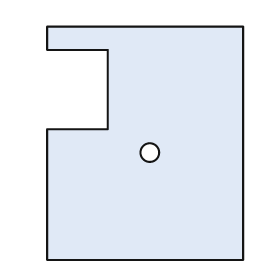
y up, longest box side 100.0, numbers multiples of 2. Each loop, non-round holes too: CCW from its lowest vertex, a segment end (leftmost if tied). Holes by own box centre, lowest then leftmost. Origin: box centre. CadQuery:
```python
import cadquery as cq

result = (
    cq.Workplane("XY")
    .moveTo(-42.0, -50.0)
    .lineTo(42.0, -50.0)
    .lineTo(42.0, 50.0)
    .lineTo(-42.0, 50.0)
    .lineTo(-42.0, 40.0)
    .lineTo(-16.0, 40.0)
    .lineTo(-16.0, 6.0)
    .lineTo(-42.0, 6.0)
    .close()
    .moveTo(2.0, -4.0)
    .circle(4.0)
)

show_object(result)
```